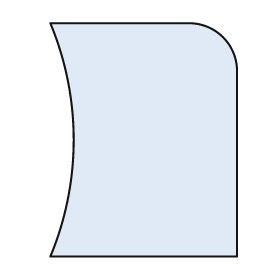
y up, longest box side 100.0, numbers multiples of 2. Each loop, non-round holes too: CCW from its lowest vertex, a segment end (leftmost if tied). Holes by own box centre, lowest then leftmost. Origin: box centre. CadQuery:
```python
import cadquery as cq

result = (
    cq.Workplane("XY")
    .moveTo(-40.0, -50.0)
    .lineTo(40.0, -50.0)
    .lineTo(40.0, 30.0)
    .threePointArc((34.0, 44.0), (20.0, 50.0))
    .lineTo(-40.0, 50.0)
    .threePointArc((-30.0, 0.0), (-40.0, -50.0))
    .close()
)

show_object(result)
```